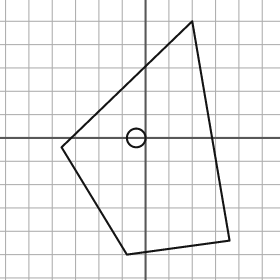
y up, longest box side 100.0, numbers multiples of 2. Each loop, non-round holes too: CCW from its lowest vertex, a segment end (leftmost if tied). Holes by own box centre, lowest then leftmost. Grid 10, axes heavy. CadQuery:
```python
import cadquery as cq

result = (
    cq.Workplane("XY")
    .moveTo(-8.0, -50.0)
    .lineTo(36.0, -44.0)
    .lineTo(20.0, 50.0)
    .lineTo(-36.0, -4.0)
    .close()
    .moveTo(-4.0, 0.0)
    .circle(4.0)
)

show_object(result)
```